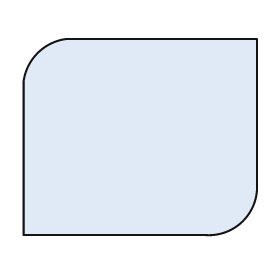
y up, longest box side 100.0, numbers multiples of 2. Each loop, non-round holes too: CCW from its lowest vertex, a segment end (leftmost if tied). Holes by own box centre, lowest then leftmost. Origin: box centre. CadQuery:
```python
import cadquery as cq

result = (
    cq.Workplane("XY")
    .moveTo(-50.0, -42.0)
    .lineTo(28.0, -42.0)
    .threePointArc((44.0, -36.0), (50.0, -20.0))
    .lineTo(50.0, 42.0)
    .lineTo(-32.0, 42.0)
    .threePointArc((-44.0, 36.0), (-50.0, 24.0))
    .close()
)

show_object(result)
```